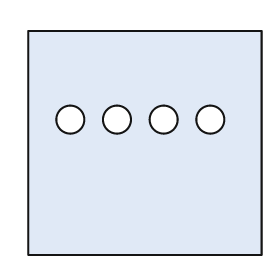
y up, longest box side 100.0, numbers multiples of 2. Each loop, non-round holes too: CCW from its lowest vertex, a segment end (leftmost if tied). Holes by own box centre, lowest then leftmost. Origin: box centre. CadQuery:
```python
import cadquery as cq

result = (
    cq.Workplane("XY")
    .moveTo(-50.0, -48.0)
    .lineTo(50.0, -48.0)
    .lineTo(50.0, 48.0)
    .lineTo(-50.0, 48.0)
    .close()
    .moveTo(-32.0, 10.0)
    .circle(6.0)
    .moveTo(-12.0, 10.0)
    .circle(6.0)
    .moveTo(8.0, 10.0)
    .circle(6.0)
    .moveTo(28.0, 10.0)
    .circle(6.0)
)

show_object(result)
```